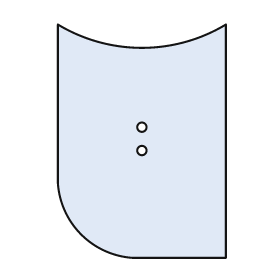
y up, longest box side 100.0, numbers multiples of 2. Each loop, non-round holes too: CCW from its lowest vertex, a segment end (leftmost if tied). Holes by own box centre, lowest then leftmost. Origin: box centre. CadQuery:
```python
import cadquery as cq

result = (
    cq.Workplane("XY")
    .moveTo(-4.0, -50.0)
    .lineTo(36.0, -50.0)
    .lineTo(36.0, 50.0)
    .threePointArc((0.0, 40.0), (-36.0, 50.0))
    .lineTo(-36.0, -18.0)
    .threePointArc((-26.0, -40.0), (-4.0, -50.0))
    .close()
    .moveTo(0.0, -4.0)
    .circle(2.0)
    .moveTo(0.0, 6.0)
    .circle(2.0)
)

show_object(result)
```